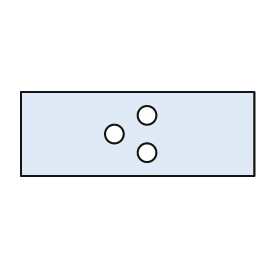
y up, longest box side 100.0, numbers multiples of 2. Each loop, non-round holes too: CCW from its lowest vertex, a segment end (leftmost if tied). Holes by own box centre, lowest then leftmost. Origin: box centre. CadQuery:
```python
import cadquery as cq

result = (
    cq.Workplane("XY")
    .moveTo(-50.0, -18.0)
    .lineTo(50.0, -18.0)
    .lineTo(50.0, 18.0)
    .lineTo(-50.0, 18.0)
    .close()
    .moveTo(4.0, -8.0)
    .circle(4.0)
    .moveTo(-10.0, 0.0)
    .circle(4.0)
    .moveTo(4.0, 8.0)
    .circle(4.0)
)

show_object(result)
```